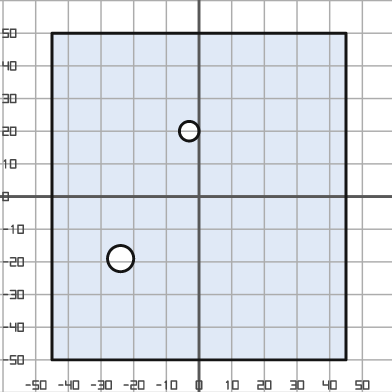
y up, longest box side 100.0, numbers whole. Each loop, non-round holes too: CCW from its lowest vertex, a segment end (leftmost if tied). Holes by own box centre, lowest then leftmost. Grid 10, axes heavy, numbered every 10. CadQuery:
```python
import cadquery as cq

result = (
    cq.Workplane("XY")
    .moveTo(-45.0, -50.0)
    .lineTo(45.0, -50.0)
    .lineTo(45.0, 50.0)
    .lineTo(-45.0, 50.0)
    .close()
    .moveTo(-24.0, -19.0)
    .circle(4.0)
    .moveTo(-3.0, 20.0)
    .circle(3.0)
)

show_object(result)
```